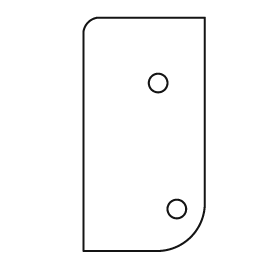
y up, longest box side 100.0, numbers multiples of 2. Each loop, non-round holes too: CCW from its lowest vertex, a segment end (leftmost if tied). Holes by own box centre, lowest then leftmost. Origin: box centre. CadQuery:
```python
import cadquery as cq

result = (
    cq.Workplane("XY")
    .moveTo(-26.0, -50.0)
    .lineTo(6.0, -50.0)
    .threePointArc((20.0, -44.0), (26.0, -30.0))
    .lineTo(26.0, 50.0)
    .lineTo(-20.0, 50.0)
    .threePointArc((-24.0, 48.0), (-26.0, 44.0))
    .close()
    .moveTo(14.0, -32.0)
    .circle(4.0)
    .moveTo(6.0, 22.0)
    .circle(4.0)
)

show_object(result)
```